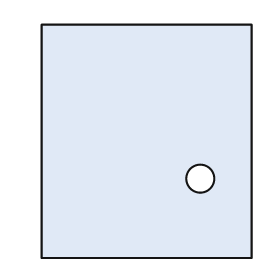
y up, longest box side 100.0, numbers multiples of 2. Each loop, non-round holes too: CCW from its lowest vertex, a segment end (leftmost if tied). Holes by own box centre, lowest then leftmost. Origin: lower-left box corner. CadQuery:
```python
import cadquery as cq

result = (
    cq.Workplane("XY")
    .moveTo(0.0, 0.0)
    .lineTo(90.0, 0.0)
    .lineTo(90.0, 100.0)
    .lineTo(0.0, 100.0)
    .close()
    .moveTo(68.0, 34.0)
    .circle(6.0)
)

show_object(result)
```